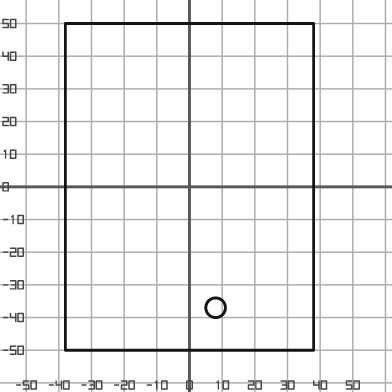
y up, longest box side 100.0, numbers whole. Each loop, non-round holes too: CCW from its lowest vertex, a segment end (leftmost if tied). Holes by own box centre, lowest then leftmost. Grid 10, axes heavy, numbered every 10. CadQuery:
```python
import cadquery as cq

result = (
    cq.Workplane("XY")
    .moveTo(-38.0, -50.0)
    .lineTo(38.0, -50.0)
    .lineTo(38.0, 50.0)
    .lineTo(-38.0, 50.0)
    .close()
    .moveTo(8.0, -37.0)
    .circle(3.0)
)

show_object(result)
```